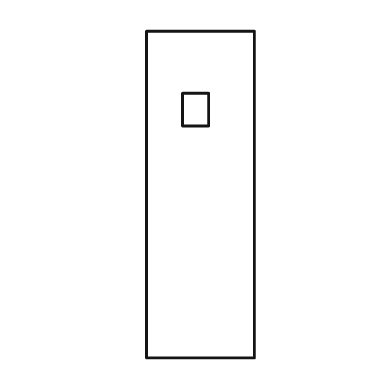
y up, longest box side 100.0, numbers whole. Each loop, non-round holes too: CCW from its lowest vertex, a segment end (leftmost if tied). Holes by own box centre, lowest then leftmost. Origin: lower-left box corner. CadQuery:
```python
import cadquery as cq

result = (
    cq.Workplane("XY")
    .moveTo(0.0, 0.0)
    .lineTo(33.0, 0.0)
    .lineTo(33.0, 100.0)
    .lineTo(0.0, 100.0)
    .close()
    .moveTo(11.0, 71.0)
    .lineTo(19.0, 71.0)
    .lineTo(19.0, 81.0)
    .lineTo(11.0, 81.0)
    .close()
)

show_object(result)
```